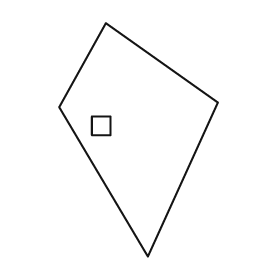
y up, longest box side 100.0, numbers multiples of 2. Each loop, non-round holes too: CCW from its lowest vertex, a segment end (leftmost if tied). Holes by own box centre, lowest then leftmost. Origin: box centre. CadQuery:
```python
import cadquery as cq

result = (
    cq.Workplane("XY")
    .moveTo(4.0, -50.0)
    .lineTo(34.0, 16.0)
    .lineTo(-14.0, 50.0)
    .lineTo(-34.0, 14.0)
    .close()
    .moveTo(-20.0, 2.0)
    .lineTo(-12.0, 2.0)
    .lineTo(-12.0, 10.0)
    .lineTo(-20.0, 10.0)
    .close()
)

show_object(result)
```